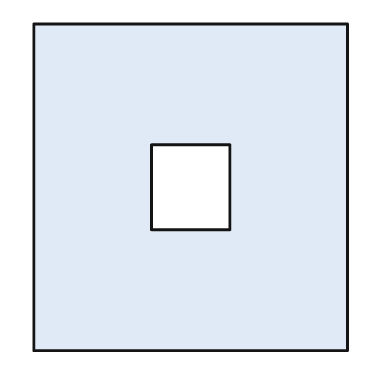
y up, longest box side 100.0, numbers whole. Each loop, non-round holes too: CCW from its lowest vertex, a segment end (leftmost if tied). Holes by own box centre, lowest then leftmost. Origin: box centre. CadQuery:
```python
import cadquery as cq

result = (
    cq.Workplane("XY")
    .moveTo(-48.0, -50.0)
    .lineTo(48.0, -50.0)
    .lineTo(48.0, 50.0)
    .lineTo(-48.0, 50.0)
    .close()
    .moveTo(-12.0, -13.0)
    .lineTo(12.0, -13.0)
    .lineTo(12.0, 13.0)
    .lineTo(-12.0, 13.0)
    .close()
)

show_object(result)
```